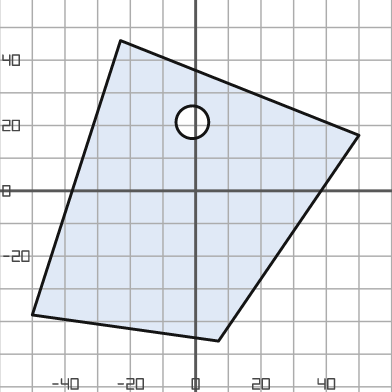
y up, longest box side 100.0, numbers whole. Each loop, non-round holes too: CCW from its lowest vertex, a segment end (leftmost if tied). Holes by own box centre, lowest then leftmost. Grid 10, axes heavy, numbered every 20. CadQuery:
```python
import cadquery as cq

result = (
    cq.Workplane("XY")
    .moveTo(7.0, -46.0)
    .lineTo(50.0, 17.0)
    .lineTo(-23.0, 46.0)
    .lineTo(-50.0, -38.0)
    .close()
    .moveTo(-1.0, 21.0)
    .circle(5.0)
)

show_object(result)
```